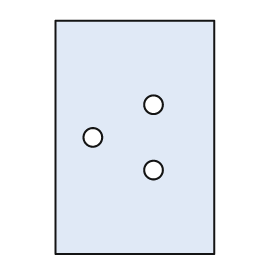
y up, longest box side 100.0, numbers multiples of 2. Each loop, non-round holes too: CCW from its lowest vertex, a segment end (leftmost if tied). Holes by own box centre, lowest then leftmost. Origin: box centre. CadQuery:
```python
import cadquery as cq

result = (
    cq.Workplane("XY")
    .moveTo(-34.0, -50.0)
    .lineTo(34.0, -50.0)
    .lineTo(34.0, 50.0)
    .lineTo(-34.0, 50.0)
    .close()
    .moveTo(8.0, -14.0)
    .circle(4.0)
    .moveTo(-18.0, 0.0)
    .circle(4.0)
    .moveTo(8.0, 14.0)
    .circle(4.0)
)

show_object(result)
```